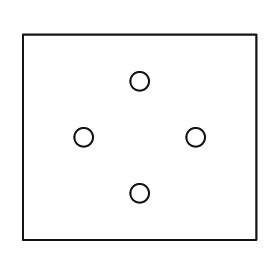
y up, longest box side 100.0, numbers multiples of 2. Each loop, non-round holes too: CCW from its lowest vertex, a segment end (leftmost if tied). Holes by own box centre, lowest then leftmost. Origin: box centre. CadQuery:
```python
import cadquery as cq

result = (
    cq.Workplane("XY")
    .moveTo(-50.0, -44.0)
    .lineTo(50.0, -44.0)
    .lineTo(50.0, 44.0)
    .lineTo(-50.0, 44.0)
    .close()
    .moveTo(0.0, -24.0)
    .circle(4.0)
    .moveTo(-24.0, 0.0)
    .circle(4.0)
    .moveTo(24.0, 0.0)
    .circle(4.0)
    .moveTo(0.0, 24.0)
    .circle(4.0)
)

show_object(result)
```